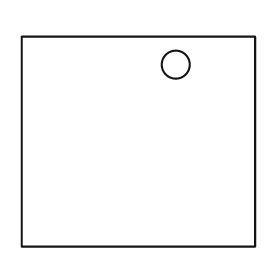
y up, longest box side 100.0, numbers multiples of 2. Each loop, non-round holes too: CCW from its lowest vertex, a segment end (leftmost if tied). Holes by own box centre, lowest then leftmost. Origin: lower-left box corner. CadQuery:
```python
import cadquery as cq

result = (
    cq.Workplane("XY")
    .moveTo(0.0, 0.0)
    .lineTo(100.0, 0.0)
    .lineTo(100.0, 90.0)
    .lineTo(0.0, 90.0)
    .close()
    .moveTo(66.0, 78.0)
    .circle(6.0)
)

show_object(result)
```